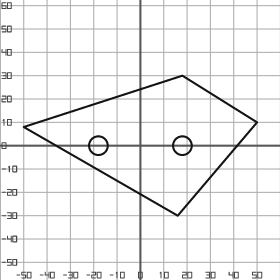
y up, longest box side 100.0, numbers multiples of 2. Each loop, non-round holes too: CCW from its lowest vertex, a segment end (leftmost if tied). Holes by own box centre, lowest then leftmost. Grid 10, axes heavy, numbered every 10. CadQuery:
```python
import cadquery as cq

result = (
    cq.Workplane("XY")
    .moveTo(16.0, -30.0)
    .lineTo(50.0, 10.0)
    .lineTo(18.0, 30.0)
    .lineTo(-50.0, 8.0)
    .close()
    .moveTo(-18.0, 0.0)
    .circle(4.0)
    .moveTo(18.0, 0.0)
    .circle(4.0)
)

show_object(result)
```